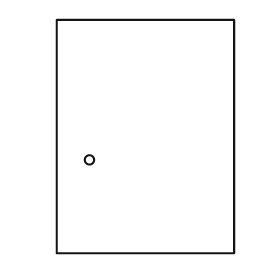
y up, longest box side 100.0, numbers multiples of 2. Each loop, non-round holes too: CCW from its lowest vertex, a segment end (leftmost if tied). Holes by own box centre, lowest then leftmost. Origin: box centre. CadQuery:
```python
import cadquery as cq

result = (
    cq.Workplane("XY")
    .moveTo(-38.0, -50.0)
    .lineTo(38.0, -50.0)
    .lineTo(38.0, 50.0)
    .lineTo(-38.0, 50.0)
    .close()
    .moveTo(-24.0, -10.0)
    .circle(2.0)
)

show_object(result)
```